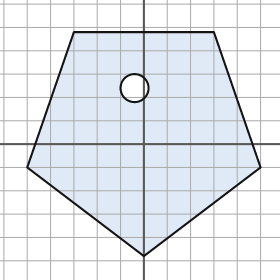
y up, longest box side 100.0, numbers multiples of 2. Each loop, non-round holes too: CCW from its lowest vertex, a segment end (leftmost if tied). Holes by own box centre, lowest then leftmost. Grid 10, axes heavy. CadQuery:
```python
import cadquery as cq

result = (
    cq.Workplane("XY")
    .moveTo(0.0, -48.0)
    .lineTo(50.0, -10.0)
    .lineTo(30.0, 48.0)
    .lineTo(-30.0, 48.0)
    .lineTo(-50.0, -10.0)
    .close()
    .moveTo(-4.0, 24.0)
    .circle(6.0)
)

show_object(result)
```